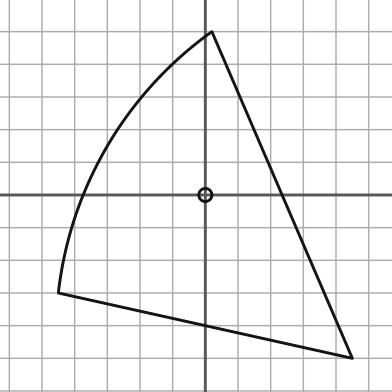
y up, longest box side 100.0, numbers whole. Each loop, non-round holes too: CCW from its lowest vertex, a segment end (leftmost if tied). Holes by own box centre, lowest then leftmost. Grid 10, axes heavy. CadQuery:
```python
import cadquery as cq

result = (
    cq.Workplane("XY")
    .moveTo(45.0, -50.0)
    .lineTo(2.0, 50.0)
    .threePointArc((-30.0, 15.0), (-45.0, -30.0))
    .close()
    .moveTo(0.0, 0.0)
    .circle(2.0)
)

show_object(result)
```